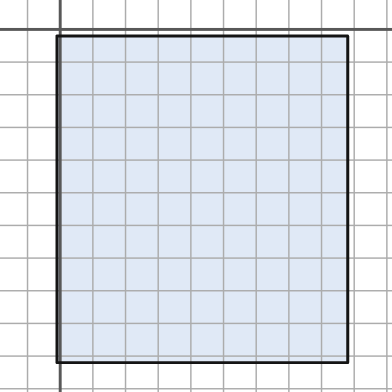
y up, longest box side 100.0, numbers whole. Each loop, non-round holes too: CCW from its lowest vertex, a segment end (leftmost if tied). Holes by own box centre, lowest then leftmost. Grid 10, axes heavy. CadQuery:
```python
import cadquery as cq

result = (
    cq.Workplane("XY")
    .moveTo(-1.0, -102.0)
    .lineTo(88.0, -102.0)
    .lineTo(88.0, -2.0)
    .lineTo(-1.0, -2.0)
    .close()
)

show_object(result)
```